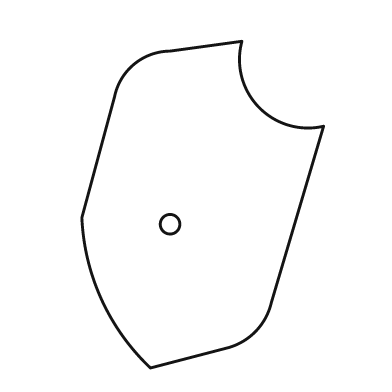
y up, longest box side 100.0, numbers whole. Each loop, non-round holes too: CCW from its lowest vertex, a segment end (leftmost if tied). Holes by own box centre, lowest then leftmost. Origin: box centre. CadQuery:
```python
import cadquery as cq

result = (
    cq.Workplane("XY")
    .moveTo(-16.0, -50.0)
    .lineTo(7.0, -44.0)
    .threePointArc((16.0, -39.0), (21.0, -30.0))
    .lineTo(37.0, 24.0)
    .threePointArc((17.0, 30.0), (12.0, 50.0))
    .lineTo(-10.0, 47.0)
    .threePointArc((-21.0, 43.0), (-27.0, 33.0))
    .lineTo(-37.0, -4.0)
    .threePointArc((-31.0, -29.0), (-16.0, -50.0))
    .close()
    .moveTo(-10.0, -6.0)
    .circle(3.0)
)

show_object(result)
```